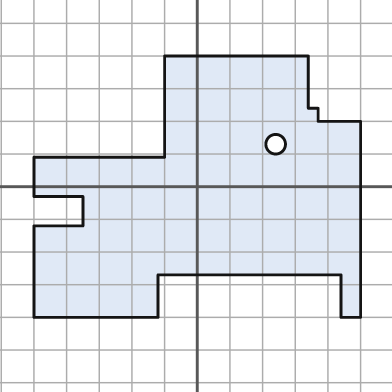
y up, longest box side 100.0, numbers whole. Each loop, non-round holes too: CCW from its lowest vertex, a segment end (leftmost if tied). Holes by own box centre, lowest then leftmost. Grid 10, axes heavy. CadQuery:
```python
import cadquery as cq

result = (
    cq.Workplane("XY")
    .moveTo(-50.0, -40.0)
    .lineTo(-12.0, -40.0)
    .lineTo(-12.0, -27.0)
    .lineTo(44.0, -27.0)
    .lineTo(44.0, -40.0)
    .lineTo(50.0, -40.0)
    .lineTo(50.0, 20.0)
    .lineTo(37.0, 20.0)
    .lineTo(37.0, 24.0)
    .lineTo(34.0, 24.0)
    .lineTo(34.0, 40.0)
    .lineTo(-10.0, 40.0)
    .lineTo(-10.0, 9.0)
    .lineTo(-50.0, 9.0)
    .lineTo(-50.0, -3.0)
    .lineTo(-35.0, -3.0)
    .lineTo(-35.0, -12.0)
    .lineTo(-50.0, -12.0)
    .close()
    .moveTo(24.0, 13.0)
    .circle(3.0)
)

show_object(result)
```